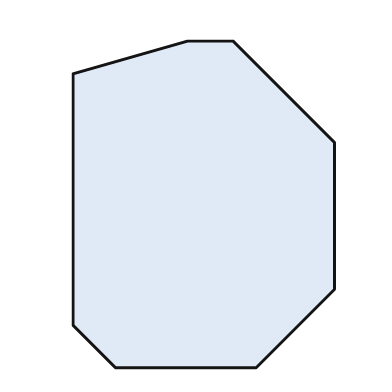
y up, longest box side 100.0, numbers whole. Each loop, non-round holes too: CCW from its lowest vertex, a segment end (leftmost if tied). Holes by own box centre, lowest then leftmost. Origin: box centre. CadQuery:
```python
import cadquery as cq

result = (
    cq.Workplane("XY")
    .moveTo(-27.0, -50.0)
    .lineTo(16.0, -50.0)
    .lineTo(40.0, -26.0)
    .lineTo(40.0, 19.0)
    .lineTo(9.0, 50.0)
    .lineTo(-5.0, 50.0)
    .lineTo(-40.0, 40.0)
    .lineTo(-40.0, -37.0)
    .close()
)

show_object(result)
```